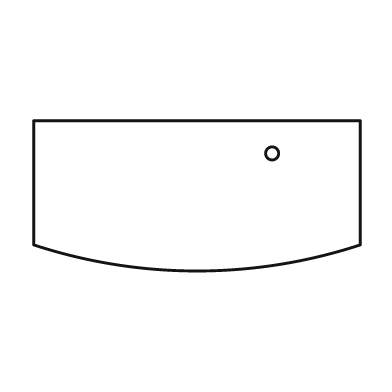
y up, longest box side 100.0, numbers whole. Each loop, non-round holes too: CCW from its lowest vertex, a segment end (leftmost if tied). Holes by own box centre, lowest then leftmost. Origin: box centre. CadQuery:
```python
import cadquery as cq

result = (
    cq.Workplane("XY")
    .moveTo(-50.0, -15.0)
    .threePointArc((0.0, -23.0), (50.0, -15.0))
    .lineTo(50.0, 23.0)
    .lineTo(-50.0, 23.0)
    .close()
    .moveTo(23.0, 13.0)
    .circle(2.0)
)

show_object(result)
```